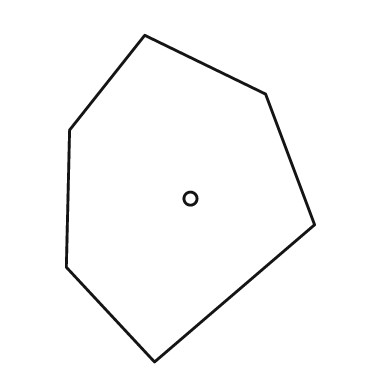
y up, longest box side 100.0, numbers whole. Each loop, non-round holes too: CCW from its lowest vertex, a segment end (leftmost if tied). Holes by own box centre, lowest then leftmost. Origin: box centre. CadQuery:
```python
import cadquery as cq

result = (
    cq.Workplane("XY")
    .moveTo(-11.0, -50.0)
    .lineTo(38.0, -8.0)
    .lineTo(23.0, 32.0)
    .lineTo(-14.0, 50.0)
    .lineTo(-37.0, 21.0)
    .lineTo(-38.0, -21.0)
    .close()
    .moveTo(0.0, 0.0)
    .circle(2.0)
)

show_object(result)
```